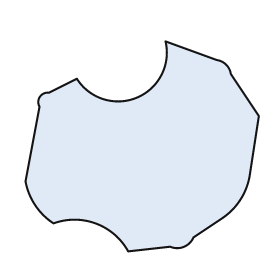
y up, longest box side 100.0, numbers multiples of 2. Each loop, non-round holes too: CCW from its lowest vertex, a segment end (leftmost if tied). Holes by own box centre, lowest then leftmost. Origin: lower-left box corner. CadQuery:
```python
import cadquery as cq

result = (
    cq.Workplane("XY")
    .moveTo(44.0, 0.0)
    .lineTo(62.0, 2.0)
    .threePointArc((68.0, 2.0), (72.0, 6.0))
    .lineTo(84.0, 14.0)
    .threePointArc((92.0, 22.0), (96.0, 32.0))
    .lineTo(100.0, 58.0)
    .lineTo(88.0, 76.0)
    .threePointArc((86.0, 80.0), (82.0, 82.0))
    .lineTo(60.0, 90.0)
    .threePointArc((48.0, 66.0), (22.0, 74.0))
    .lineTo(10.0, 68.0)
    .threePointArc((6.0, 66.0), (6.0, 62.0))
    .lineTo(0.0, 30.0)
    .threePointArc((4.0, 20.0), (12.0, 12.0))
    .threePointArc((30.0, 12.0), (44.0, 0.0))
    .close()
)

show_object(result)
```